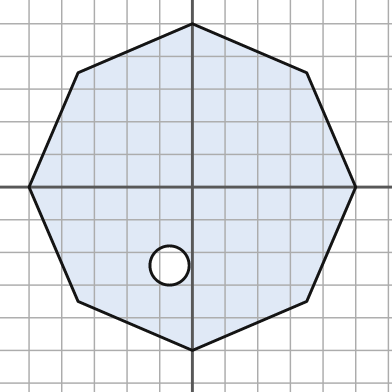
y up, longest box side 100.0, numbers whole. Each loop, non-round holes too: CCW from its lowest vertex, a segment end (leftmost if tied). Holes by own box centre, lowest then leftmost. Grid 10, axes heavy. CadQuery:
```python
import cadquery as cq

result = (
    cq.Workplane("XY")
    .moveTo(0.0, -50.0)
    .lineTo(35.0, -35.0)
    .lineTo(50.0, 0.0)
    .lineTo(35.0, 35.0)
    .lineTo(0.0, 50.0)
    .lineTo(-35.0, 35.0)
    .lineTo(-50.0, 0.0)
    .lineTo(-35.0, -35.0)
    .close()
    .moveTo(-7.0, -24.0)
    .circle(6.0)
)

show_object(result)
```